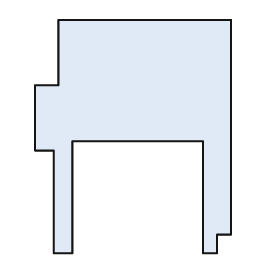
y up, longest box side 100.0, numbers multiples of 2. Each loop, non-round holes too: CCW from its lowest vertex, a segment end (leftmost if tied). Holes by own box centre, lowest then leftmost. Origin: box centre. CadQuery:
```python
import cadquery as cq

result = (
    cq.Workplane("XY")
    .moveTo(-34.0, -50.0)
    .lineTo(-26.0, -50.0)
    .lineTo(-26.0, -2.0)
    .lineTo(30.0, -2.0)
    .lineTo(30.0, -50.0)
    .lineTo(36.0, -50.0)
    .lineTo(36.0, -42.0)
    .lineTo(42.0, -42.0)
    .lineTo(42.0, 50.0)
    .lineTo(-32.0, 50.0)
    .lineTo(-32.0, 22.0)
    .lineTo(-42.0, 22.0)
    .lineTo(-42.0, -6.0)
    .lineTo(-34.0, -6.0)
    .close()
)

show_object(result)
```